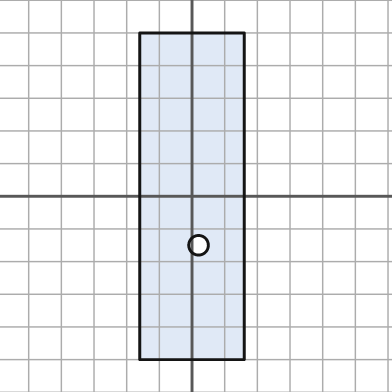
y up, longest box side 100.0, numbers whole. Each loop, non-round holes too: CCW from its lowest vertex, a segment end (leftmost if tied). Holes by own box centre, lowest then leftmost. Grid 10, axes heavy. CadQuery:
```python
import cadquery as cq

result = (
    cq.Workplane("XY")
    .moveTo(-16.0, -50.0)
    .lineTo(16.0, -50.0)
    .lineTo(16.0, 50.0)
    .lineTo(-16.0, 50.0)
    .close()
    .moveTo(2.0, -15.0)
    .circle(3.0)
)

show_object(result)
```